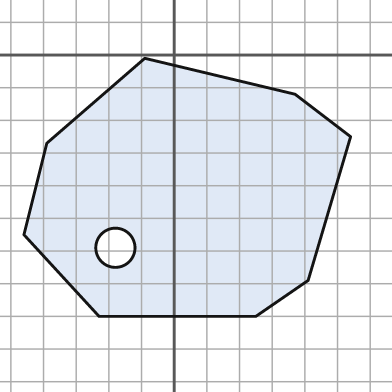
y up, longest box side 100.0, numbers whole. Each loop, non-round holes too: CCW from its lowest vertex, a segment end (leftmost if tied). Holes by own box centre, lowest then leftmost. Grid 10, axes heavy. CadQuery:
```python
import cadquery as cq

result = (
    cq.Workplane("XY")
    .moveTo(-23.0, -80.0)
    .lineTo(25.0, -80.0)
    .lineTo(41.0, -69.0)
    .lineTo(54.0, -25.0)
    .lineTo(37.0, -12.0)
    .lineTo(-9.0, -1.0)
    .lineTo(-39.0, -27.0)
    .lineTo(-46.0, -55.0)
    .close()
    .moveTo(-18.0, -59.0)
    .circle(6.0)
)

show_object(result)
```